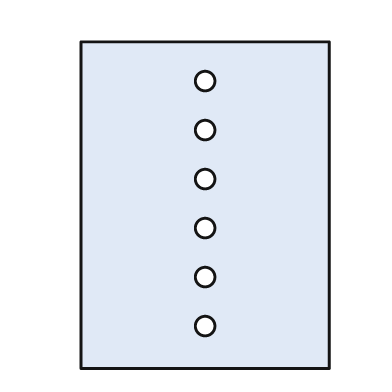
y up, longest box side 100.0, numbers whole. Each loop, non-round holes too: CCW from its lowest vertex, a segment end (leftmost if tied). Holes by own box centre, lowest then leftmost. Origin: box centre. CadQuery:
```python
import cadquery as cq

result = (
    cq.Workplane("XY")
    .moveTo(-38.0, -50.0)
    .lineTo(38.0, -50.0)
    .lineTo(38.0, 50.0)
    .lineTo(-38.0, 50.0)
    .close()
    .moveTo(0.0, -37.0)
    .circle(3.0)
    .moveTo(0.0, -22.0)
    .circle(3.0)
    .moveTo(0.0, -7.0)
    .circle(3.0)
    .moveTo(0.0, 8.0)
    .circle(3.0)
    .moveTo(0.0, 23.0)
    .circle(3.0)
    .moveTo(0.0, 38.0)
    .circle(3.0)
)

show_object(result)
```